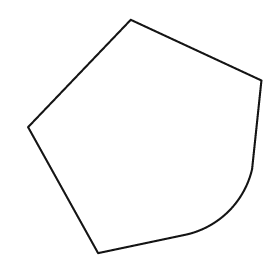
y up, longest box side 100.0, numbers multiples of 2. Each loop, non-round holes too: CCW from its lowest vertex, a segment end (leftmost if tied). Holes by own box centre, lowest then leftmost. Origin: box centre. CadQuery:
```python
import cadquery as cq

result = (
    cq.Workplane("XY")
    .moveTo(-20.0, -50.0)
    .lineTo(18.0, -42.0)
    .threePointArc((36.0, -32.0), (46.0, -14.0))
    .lineTo(50.0, 24.0)
    .lineTo(-6.0, 50.0)
    .lineTo(-50.0, 4.0)
    .close()
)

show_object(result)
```